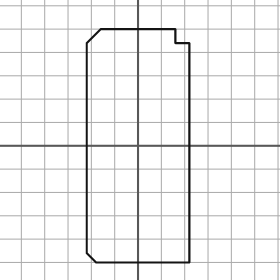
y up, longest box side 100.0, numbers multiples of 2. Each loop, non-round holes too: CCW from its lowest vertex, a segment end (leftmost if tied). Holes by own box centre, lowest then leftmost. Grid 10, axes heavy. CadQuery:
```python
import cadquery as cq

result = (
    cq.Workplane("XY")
    .moveTo(-18.0, -50.0)
    .lineTo(22.0, -50.0)
    .lineTo(22.0, 44.0)
    .lineTo(16.0, 44.0)
    .lineTo(16.0, 50.0)
    .lineTo(-16.0, 50.0)
    .lineTo(-22.0, 44.0)
    .lineTo(-22.0, -46.0)
    .close()
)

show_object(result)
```